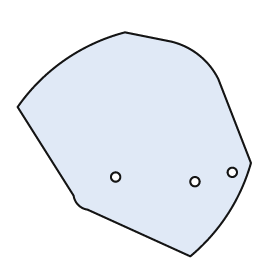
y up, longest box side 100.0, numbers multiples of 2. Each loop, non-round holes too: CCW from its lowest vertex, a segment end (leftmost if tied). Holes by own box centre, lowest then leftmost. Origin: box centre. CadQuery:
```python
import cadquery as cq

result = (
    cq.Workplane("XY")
    .moveTo(24.0, -48.0)
    .threePointArc((40.0, -30.0), (50.0, -8.0))
    .lineTo(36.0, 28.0)
    .threePointArc((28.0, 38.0), (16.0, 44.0))
    .lineTo(-4.0, 48.0)
    .threePointArc((-30.0, 36.0), (-50.0, 16.0))
    .lineTo(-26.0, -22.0)
    .threePointArc((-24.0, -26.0), (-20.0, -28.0))
    .close()
    .moveTo(26.0, -16.0)
    .circle(2.0)
    .moveTo(-8.0, -14.0)
    .circle(2.0)
    .moveTo(42.0, -12.0)
    .circle(2.0)
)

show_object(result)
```